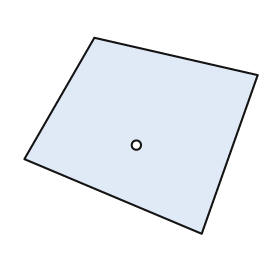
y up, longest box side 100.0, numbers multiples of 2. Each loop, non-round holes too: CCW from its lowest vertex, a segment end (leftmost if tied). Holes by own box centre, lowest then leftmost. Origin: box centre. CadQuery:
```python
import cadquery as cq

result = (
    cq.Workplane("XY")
    .moveTo(26.0, -42.0)
    .lineTo(50.0, 26.0)
    .lineTo(-20.0, 42.0)
    .lineTo(-50.0, -10.0)
    .close()
    .moveTo(-2.0, -4.0)
    .circle(2.0)
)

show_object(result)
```